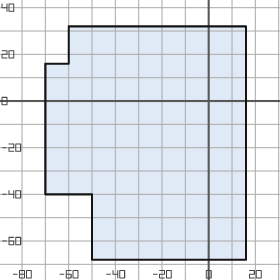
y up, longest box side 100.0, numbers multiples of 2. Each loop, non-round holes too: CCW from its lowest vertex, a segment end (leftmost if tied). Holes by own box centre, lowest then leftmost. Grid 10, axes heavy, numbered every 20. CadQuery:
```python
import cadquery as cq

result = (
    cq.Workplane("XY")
    .moveTo(-50.0, -68.0)
    .lineTo(16.0, -68.0)
    .lineTo(16.0, 32.0)
    .lineTo(-60.0, 32.0)
    .lineTo(-60.0, 16.0)
    .lineTo(-70.0, 16.0)
    .lineTo(-70.0, -40.0)
    .lineTo(-50.0, -40.0)
    .close()
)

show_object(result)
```